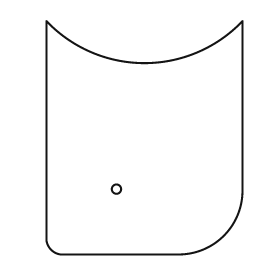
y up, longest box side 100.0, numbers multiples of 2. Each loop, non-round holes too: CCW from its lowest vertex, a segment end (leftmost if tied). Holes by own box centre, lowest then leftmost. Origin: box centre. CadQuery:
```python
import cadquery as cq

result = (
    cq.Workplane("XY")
    .moveTo(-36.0, -50.0)
    .lineTo(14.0, -50.0)
    .threePointArc((34.0, -42.0), (42.0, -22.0))
    .lineTo(42.0, 50.0)
    .threePointArc((0.0, 32.0), (-42.0, 50.0))
    .lineTo(-42.0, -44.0)
    .threePointArc((-40.0, -48.0), (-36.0, -50.0))
    .close()
    .moveTo(-12.0, -22.0)
    .circle(2.0)
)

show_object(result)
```